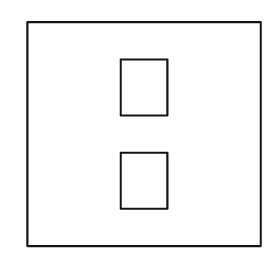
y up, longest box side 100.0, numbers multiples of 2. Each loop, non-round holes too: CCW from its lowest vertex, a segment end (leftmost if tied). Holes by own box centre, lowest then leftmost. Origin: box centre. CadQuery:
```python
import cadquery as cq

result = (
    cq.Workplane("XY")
    .moveTo(-50.0, -48.0)
    .lineTo(50.0, -48.0)
    .lineTo(50.0, 48.0)
    .lineTo(-50.0, 48.0)
    .close()
    .moveTo(-10.0, -32.0)
    .lineTo(10.0, -32.0)
    .lineTo(10.0, -8.0)
    .lineTo(-10.0, -8.0)
    .close()
    .moveTo(-10.0, 8.0)
    .lineTo(10.0, 8.0)
    .lineTo(10.0, 32.0)
    .lineTo(-10.0, 32.0)
    .close()
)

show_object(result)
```